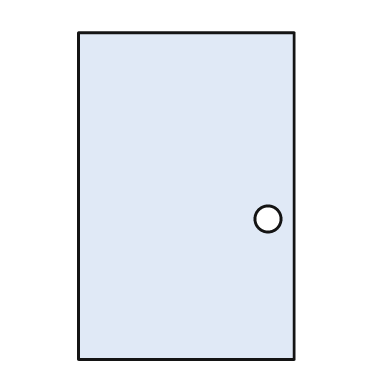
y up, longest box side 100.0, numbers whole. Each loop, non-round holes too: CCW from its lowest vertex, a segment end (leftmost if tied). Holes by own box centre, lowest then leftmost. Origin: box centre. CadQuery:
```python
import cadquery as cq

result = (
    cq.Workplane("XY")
    .moveTo(-33.0, -50.0)
    .lineTo(33.0, -50.0)
    .lineTo(33.0, 50.0)
    .lineTo(-33.0, 50.0)
    .close()
    .moveTo(25.0, -7.0)
    .circle(4.0)
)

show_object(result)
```